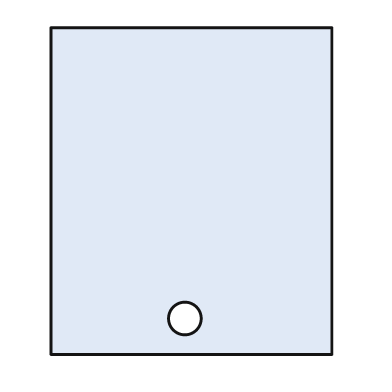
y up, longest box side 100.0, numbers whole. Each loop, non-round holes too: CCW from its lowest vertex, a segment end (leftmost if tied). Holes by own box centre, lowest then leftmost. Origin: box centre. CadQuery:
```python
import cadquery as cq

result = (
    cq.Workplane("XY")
    .moveTo(-43.0, -50.0)
    .lineTo(43.0, -50.0)
    .lineTo(43.0, 50.0)
    .lineTo(-43.0, 50.0)
    .close()
    .moveTo(-2.0, -39.0)
    .circle(5.0)
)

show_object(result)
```